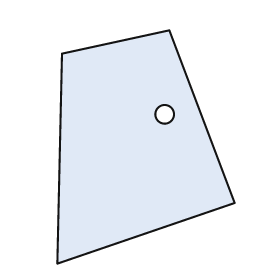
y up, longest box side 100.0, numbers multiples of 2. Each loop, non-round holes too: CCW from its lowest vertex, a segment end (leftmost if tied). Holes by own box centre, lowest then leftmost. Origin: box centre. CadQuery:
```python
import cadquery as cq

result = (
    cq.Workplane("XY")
    .moveTo(-38.0, -50.0)
    .lineTo(38.0, -24.0)
    .lineTo(10.0, 50.0)
    .lineTo(-36.0, 40.0)
    .close()
    .moveTo(8.0, 14.0)
    .circle(4.0)
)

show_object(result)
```